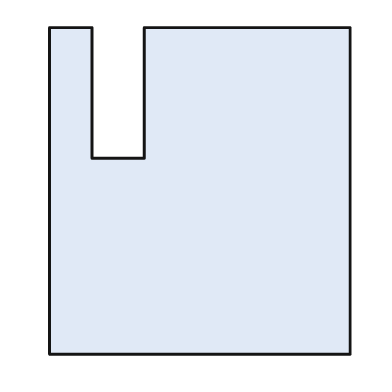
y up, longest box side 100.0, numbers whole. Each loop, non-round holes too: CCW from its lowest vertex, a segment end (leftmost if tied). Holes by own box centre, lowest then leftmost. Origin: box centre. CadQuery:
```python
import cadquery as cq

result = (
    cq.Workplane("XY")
    .moveTo(-46.0, -50.0)
    .lineTo(46.0, -50.0)
    .lineTo(46.0, 50.0)
    .lineTo(-17.0, 50.0)
    .lineTo(-17.0, 10.0)
    .lineTo(-33.0, 10.0)
    .lineTo(-33.0, 50.0)
    .lineTo(-46.0, 50.0)
    .close()
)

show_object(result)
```